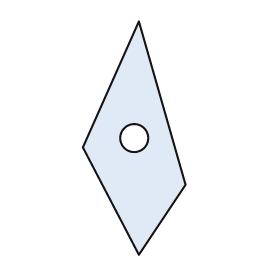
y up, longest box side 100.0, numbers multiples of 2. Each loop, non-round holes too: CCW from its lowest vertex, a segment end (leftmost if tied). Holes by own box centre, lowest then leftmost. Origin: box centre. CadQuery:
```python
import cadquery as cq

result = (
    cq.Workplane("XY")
    .moveTo(2.0, -50.0)
    .lineTo(22.0, -20.0)
    .lineTo(2.0, 50.0)
    .lineTo(-22.0, -4.0)
    .close()
    .moveTo(0.0, 0.0)
    .circle(6.0)
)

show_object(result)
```